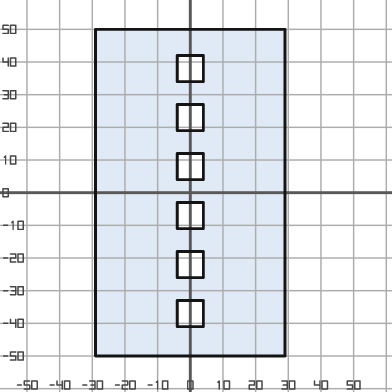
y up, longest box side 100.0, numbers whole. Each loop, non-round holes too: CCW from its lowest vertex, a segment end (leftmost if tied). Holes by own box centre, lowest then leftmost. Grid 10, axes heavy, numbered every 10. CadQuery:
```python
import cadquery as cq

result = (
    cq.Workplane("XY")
    .moveTo(-29.0, -50.0)
    .lineTo(29.0, -50.0)
    .lineTo(29.0, 50.0)
    .lineTo(-29.0, 50.0)
    .close()
    .moveTo(-4.0, -41.0)
    .lineTo(4.0, -41.0)
    .lineTo(4.0, -33.0)
    .lineTo(-4.0, -33.0)
    .close()
    .moveTo(-4.0, -26.0)
    .lineTo(4.0, -26.0)
    .lineTo(4.0, -18.0)
    .lineTo(-4.0, -18.0)
    .close()
    .moveTo(-4.0, -11.0)
    .lineTo(4.0, -11.0)
    .lineTo(4.0, -3.0)
    .lineTo(-4.0, -3.0)
    .close()
    .moveTo(-4.0, 4.0)
    .lineTo(4.0, 4.0)
    .lineTo(4.0, 12.0)
    .lineTo(-4.0, 12.0)
    .close()
    .moveTo(-4.0, 19.0)
    .lineTo(4.0, 19.0)
    .lineTo(4.0, 27.0)
    .lineTo(-4.0, 27.0)
    .close()
    .moveTo(-4.0, 34.0)
    .lineTo(4.0, 34.0)
    .lineTo(4.0, 42.0)
    .lineTo(-4.0, 42.0)
    .close()
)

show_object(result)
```